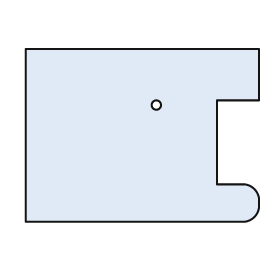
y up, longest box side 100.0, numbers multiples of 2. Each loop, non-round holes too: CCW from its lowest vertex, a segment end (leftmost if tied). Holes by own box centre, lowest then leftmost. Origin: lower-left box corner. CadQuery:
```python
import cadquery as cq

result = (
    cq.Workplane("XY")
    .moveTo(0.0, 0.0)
    .lineTo(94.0, 0.0)
    .threePointArc((98.0, 2.0), (100.0, 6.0))
    .lineTo(100.0, 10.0)
    .threePointArc((98.0, 14.0), (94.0, 16.0))
    .lineTo(82.0, 16.0)
    .lineTo(82.0, 52.0)
    .lineTo(100.0, 52.0)
    .lineTo(100.0, 74.0)
    .lineTo(0.0, 74.0)
    .close()
    .moveTo(56.0, 50.0)
    .circle(2.0)
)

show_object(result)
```